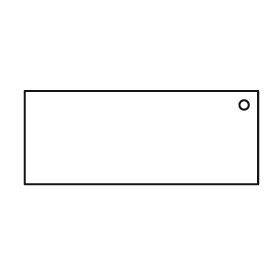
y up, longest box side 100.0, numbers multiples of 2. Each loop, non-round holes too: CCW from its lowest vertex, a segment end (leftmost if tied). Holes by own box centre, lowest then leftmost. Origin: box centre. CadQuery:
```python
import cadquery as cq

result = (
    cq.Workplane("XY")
    .moveTo(-50.0, -20.0)
    .lineTo(50.0, -20.0)
    .lineTo(50.0, 20.0)
    .lineTo(-50.0, 20.0)
    .close()
    .moveTo(44.0, 14.0)
    .circle(2.0)
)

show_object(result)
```